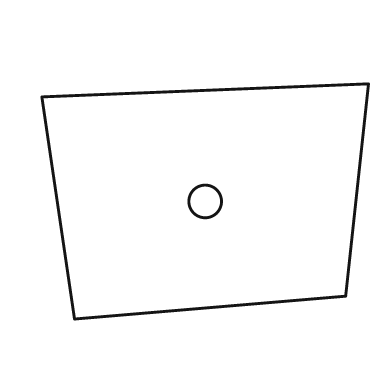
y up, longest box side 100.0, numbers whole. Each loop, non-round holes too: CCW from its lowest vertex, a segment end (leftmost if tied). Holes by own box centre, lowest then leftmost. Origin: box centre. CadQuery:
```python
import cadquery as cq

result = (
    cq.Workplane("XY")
    .moveTo(-40.0, -36.0)
    .lineTo(43.0, -29.0)
    .lineTo(50.0, 36.0)
    .lineTo(-50.0, 32.0)
    .close()
    .moveTo(0.0, 0.0)
    .circle(5.0)
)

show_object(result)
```